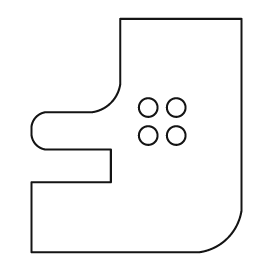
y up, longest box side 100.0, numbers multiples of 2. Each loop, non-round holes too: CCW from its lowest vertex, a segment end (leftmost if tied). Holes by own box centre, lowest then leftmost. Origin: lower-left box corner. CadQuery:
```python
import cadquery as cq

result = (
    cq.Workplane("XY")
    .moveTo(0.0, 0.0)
    .lineTo(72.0, 0.0)
    .threePointArc((84.0, 6.0), (90.0, 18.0))
    .lineTo(90.0, 100.0)
    .lineTo(38.0, 100.0)
    .lineTo(38.0, 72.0)
    .threePointArc((34.0, 64.0), (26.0, 60.0))
    .lineTo(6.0, 60.0)
    .threePointArc((2.0, 58.0), (0.0, 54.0))
    .lineTo(0.0, 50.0)
    .threePointArc((2.0, 46.0), (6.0, 44.0))
    .lineTo(34.0, 44.0)
    .lineTo(34.0, 30.0)
    .lineTo(0.0, 30.0)
    .close()
    .moveTo(50.0, 50.0)
    .circle(4.0)
    .moveTo(62.0, 50.0)
    .circle(4.0)
    .moveTo(50.0, 62.0)
    .circle(4.0)
    .moveTo(62.0, 62.0)
    .circle(4.0)
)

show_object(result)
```